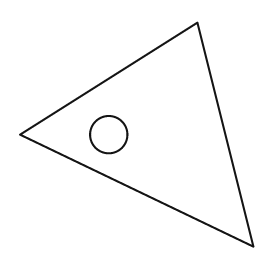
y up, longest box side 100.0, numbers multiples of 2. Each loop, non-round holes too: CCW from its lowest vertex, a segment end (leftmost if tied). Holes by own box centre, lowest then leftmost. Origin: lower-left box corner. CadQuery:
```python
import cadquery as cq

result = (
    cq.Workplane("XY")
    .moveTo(100.0, 0.0)
    .lineTo(76.0, 96.0)
    .lineTo(0.0, 48.0)
    .close()
    .moveTo(38.0, 48.0)
    .circle(8.0)
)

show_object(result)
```